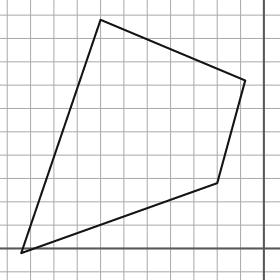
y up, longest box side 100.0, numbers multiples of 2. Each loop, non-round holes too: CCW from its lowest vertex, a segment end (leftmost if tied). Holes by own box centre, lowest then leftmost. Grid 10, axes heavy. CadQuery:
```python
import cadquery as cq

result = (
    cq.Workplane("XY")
    .moveTo(-104.0, -2.0)
    .lineTo(-20.0, 28.0)
    .lineTo(-8.0, 72.0)
    .lineTo(-70.0, 98.0)
    .close()
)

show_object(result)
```